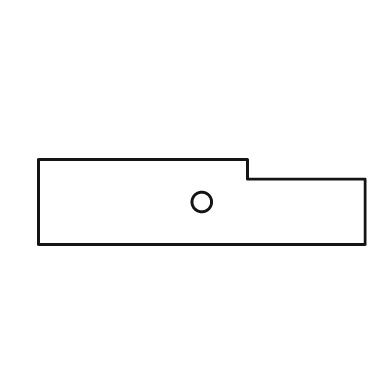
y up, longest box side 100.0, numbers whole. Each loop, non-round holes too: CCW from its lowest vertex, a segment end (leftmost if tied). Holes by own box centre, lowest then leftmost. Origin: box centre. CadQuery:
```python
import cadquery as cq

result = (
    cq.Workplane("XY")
    .moveTo(-50.0, -13.0)
    .lineTo(50.0, -13.0)
    .lineTo(50.0, 7.0)
    .lineTo(14.0, 7.0)
    .lineTo(14.0, 13.0)
    .lineTo(-50.0, 13.0)
    .close()
    .moveTo(0.0, 0.0)
    .circle(3.0)
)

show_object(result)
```